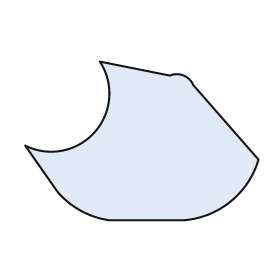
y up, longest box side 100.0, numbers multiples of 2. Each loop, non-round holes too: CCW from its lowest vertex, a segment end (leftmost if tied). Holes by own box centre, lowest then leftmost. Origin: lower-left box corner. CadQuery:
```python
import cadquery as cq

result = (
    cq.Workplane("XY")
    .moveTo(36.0, 0.0)
    .lineTo(68.0, 0.0)
    .threePointArc((88.0, 8.0), (100.0, 26.0))
    .lineTo(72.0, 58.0)
    .threePointArc((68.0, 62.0), (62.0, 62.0))
    .lineTo(32.0, 68.0)
    .threePointArc((30.0, 38.0), (0.0, 32.0))
    .lineTo(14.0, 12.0)
    .threePointArc((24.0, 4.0), (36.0, 0.0))
    .close()
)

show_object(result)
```